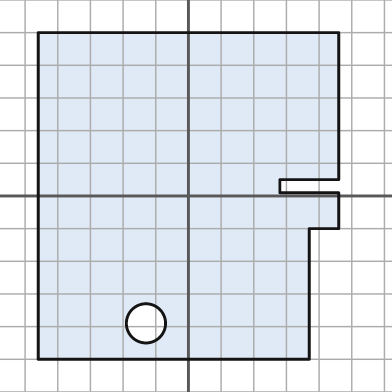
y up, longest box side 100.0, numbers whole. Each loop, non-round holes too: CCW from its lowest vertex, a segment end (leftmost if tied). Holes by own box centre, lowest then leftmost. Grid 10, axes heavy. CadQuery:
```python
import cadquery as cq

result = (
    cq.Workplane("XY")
    .moveTo(-46.0, -50.0)
    .lineTo(37.0, -50.0)
    .lineTo(37.0, -10.0)
    .lineTo(46.0, -10.0)
    .lineTo(46.0, 1.0)
    .lineTo(28.0, 1.0)
    .lineTo(28.0, 5.0)
    .lineTo(46.0, 5.0)
    .lineTo(46.0, 50.0)
    .lineTo(-46.0, 50.0)
    .close()
    .moveTo(-13.0, -39.0)
    .circle(6.0)
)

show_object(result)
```